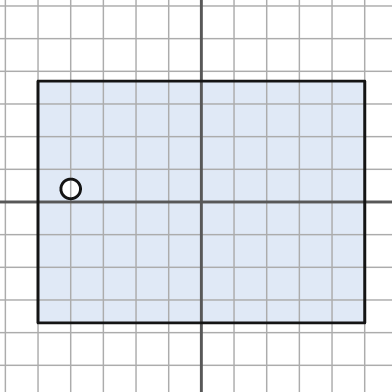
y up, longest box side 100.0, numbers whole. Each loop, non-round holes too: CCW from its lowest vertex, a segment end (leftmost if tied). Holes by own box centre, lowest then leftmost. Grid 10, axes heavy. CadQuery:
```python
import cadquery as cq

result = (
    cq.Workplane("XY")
    .moveTo(-50.0, -37.0)
    .lineTo(50.0, -37.0)
    .lineTo(50.0, 37.0)
    .lineTo(-50.0, 37.0)
    .close()
    .moveTo(-40.0, 4.0)
    .circle(3.0)
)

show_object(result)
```